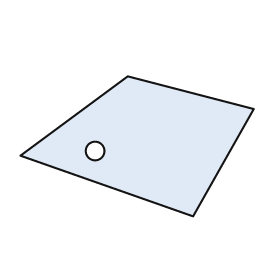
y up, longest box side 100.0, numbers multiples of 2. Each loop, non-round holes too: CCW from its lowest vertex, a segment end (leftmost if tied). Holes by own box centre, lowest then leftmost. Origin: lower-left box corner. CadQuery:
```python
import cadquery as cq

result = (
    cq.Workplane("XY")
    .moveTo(74.0, 0.0)
    .lineTo(100.0, 46.0)
    .lineTo(46.0, 60.0)
    .lineTo(0.0, 26.0)
    .close()
    .moveTo(32.0, 28.0)
    .circle(4.0)
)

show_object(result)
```